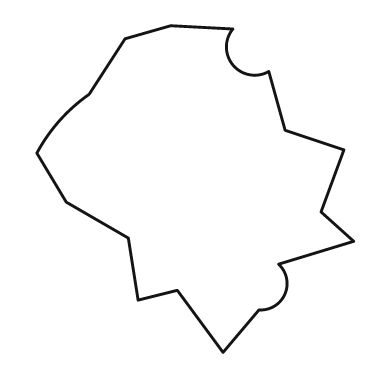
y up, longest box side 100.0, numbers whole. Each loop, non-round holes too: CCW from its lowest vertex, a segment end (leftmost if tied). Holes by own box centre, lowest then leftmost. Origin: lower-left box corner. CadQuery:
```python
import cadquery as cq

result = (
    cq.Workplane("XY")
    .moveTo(57.0, 0.0)
    .lineTo(68.0, 13.0)
    .threePointArc((76.0, 18.0), (74.0, 27.0))
    .lineTo(97.0, 34.0)
    .lineTo(87.0, 43.0)
    .lineTo(94.0, 62.0)
    .lineTo(76.0, 68.0)
    .lineTo(71.0, 86.0)
    .threePointArc((60.0, 88.0), (60.0, 99.0))
    .lineTo(41.0, 100.0)
    .lineTo(27.0, 96.0)
    .lineTo(16.0, 79.0)
    .threePointArc((7.0, 71.0), (0.0, 61.0))
    .lineTo(9.0, 46.0)
    .lineTo(28.0, 35.0)
    .lineTo(31.0, 16.0)
    .lineTo(43.0, 19.0)
    .close()
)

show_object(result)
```